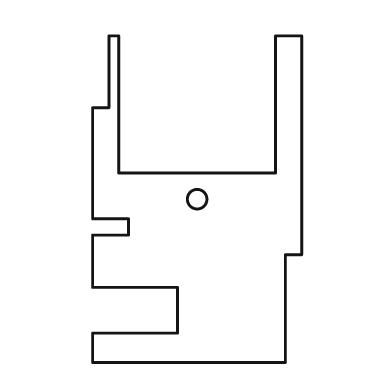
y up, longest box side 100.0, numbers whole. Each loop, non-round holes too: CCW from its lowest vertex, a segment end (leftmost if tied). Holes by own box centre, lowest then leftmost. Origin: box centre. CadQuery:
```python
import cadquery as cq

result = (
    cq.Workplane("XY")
    .moveTo(-32.0, -50.0)
    .lineTo(27.0, -50.0)
    .lineTo(27.0, -17.0)
    .lineTo(32.0, -17.0)
    .lineTo(32.0, 50.0)
    .lineTo(24.0, 50.0)
    .lineTo(24.0, 8.0)
    .lineTo(-24.0, 8.0)
    .lineTo(-24.0, 50.0)
    .lineTo(-27.0, 50.0)
    .lineTo(-27.0, 28.0)
    .lineTo(-32.0, 28.0)
    .lineTo(-32.0, -6.0)
    .lineTo(-21.0, -6.0)
    .lineTo(-21.0, -11.0)
    .lineTo(-32.0, -11.0)
    .lineTo(-32.0, -27.0)
    .lineTo(-6.0, -27.0)
    .lineTo(-6.0, -41.0)
    .lineTo(-32.0, -41.0)
    .close()
    .moveTo(0.0, 0.0)
    .circle(3.0)
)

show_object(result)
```